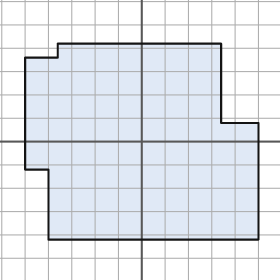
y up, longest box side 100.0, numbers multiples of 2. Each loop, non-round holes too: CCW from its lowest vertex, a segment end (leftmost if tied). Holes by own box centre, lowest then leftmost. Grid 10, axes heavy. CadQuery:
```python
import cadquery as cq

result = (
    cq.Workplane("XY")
    .moveTo(-40.0, -42.0)
    .lineTo(50.0, -42.0)
    .lineTo(50.0, 8.0)
    .lineTo(34.0, 8.0)
    .lineTo(34.0, 42.0)
    .lineTo(-36.0, 42.0)
    .lineTo(-36.0, 36.0)
    .lineTo(-50.0, 36.0)
    .lineTo(-50.0, -12.0)
    .lineTo(-40.0, -12.0)
    .close()
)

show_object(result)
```